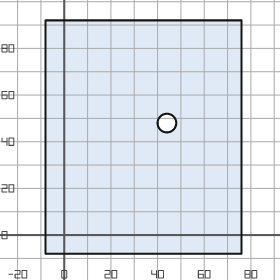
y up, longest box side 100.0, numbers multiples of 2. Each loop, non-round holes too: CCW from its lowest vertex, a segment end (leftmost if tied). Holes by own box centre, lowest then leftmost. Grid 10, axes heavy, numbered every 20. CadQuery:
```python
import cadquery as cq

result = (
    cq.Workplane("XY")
    .moveTo(-8.0, -8.0)
    .lineTo(76.0, -8.0)
    .lineTo(76.0, 92.0)
    .lineTo(-8.0, 92.0)
    .close()
    .moveTo(44.0, 48.0)
    .circle(4.0)
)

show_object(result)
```